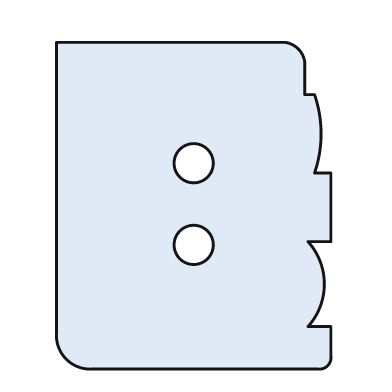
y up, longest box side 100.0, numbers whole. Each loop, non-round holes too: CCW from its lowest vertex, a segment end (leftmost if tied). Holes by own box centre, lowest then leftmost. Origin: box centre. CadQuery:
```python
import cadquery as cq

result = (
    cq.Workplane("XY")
    .moveTo(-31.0, -50.0)
    .lineTo(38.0, -50.0)
    .threePointArc((41.0, -49.0), (42.0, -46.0))
    .lineTo(42.0, -37.0)
    .lineTo(35.0, -37.0)
    .threePointArc((40.0, -24.0), (35.0, -11.0))
    .lineTo(42.0, -11.0)
    .lineTo(42.0, 10.0)
    .lineTo(37.0, 10.0)
    .threePointArc((39.0, 22.0), (37.0, 34.0))
    .lineTo(34.0, 34.0)
    .lineTo(34.0, 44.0)
    .threePointArc((32.0, 48.0), (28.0, 50.0))
    .lineTo(-42.0, 50.0)
    .lineTo(-42.0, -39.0)
    .threePointArc((-39.0, -47.0), (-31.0, -50.0))
    .close()
    .moveTo(0.0, -12.0)
    .circle(6.0)
    .moveTo(0.0, 13.0)
    .circle(6.0)
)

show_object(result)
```